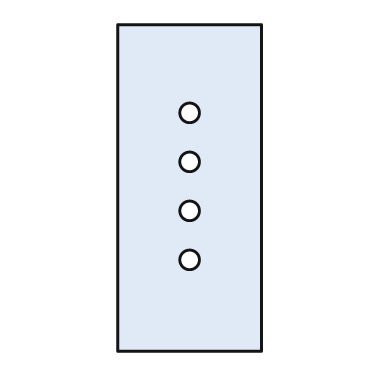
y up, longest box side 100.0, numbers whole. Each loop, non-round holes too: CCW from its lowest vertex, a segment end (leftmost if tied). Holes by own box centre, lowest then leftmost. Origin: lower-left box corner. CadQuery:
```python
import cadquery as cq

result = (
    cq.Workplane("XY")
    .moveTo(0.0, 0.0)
    .lineTo(44.0, 0.0)
    .lineTo(44.0, 100.0)
    .lineTo(0.0, 100.0)
    .close()
    .moveTo(22.0, 28.0)
    .circle(3.0)
    .moveTo(22.0, 43.0)
    .circle(3.0)
    .moveTo(22.0, 58.0)
    .circle(3.0)
    .moveTo(22.0, 73.0)
    .circle(3.0)
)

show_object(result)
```